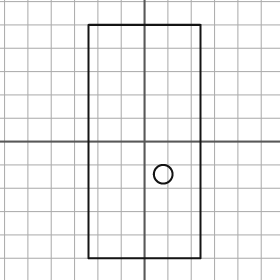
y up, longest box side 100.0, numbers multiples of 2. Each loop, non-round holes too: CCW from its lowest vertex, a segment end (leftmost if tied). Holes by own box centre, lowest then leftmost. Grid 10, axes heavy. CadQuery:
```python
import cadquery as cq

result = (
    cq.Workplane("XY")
    .moveTo(-24.0, -50.0)
    .lineTo(24.0, -50.0)
    .lineTo(24.0, 50.0)
    .lineTo(-24.0, 50.0)
    .close()
    .moveTo(8.0, -14.0)
    .circle(4.0)
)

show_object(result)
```